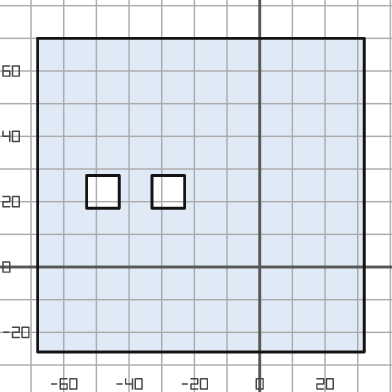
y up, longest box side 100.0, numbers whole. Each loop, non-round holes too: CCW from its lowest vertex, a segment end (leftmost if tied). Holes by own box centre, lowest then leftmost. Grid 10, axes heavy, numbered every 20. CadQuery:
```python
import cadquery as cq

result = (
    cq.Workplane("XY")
    .moveTo(-68.0, -26.0)
    .lineTo(32.0, -26.0)
    .lineTo(32.0, 70.0)
    .lineTo(-68.0, 70.0)
    .close()
    .moveTo(-53.0, 18.0)
    .lineTo(-43.0, 18.0)
    .lineTo(-43.0, 28.0)
    .lineTo(-53.0, 28.0)
    .close()
    .moveTo(-33.0, 18.0)
    .lineTo(-23.0, 18.0)
    .lineTo(-23.0, 28.0)
    .lineTo(-33.0, 28.0)
    .close()
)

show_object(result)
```